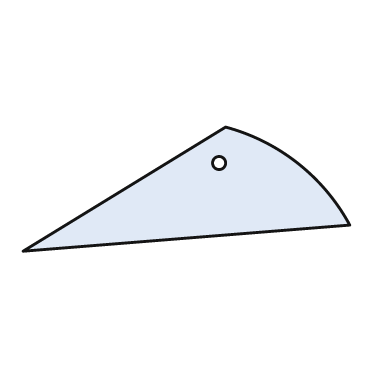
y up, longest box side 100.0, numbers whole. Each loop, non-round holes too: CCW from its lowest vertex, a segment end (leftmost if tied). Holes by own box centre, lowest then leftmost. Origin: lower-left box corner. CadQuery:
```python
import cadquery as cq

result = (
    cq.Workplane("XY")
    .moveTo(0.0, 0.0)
    .lineTo(100.0, 8.0)
    .threePointArc((84.0, 27.0), (62.0, 38.0))
    .close()
    .moveTo(60.0, 27.0)
    .circle(2.0)
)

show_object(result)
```